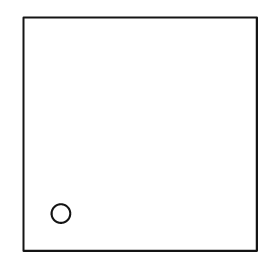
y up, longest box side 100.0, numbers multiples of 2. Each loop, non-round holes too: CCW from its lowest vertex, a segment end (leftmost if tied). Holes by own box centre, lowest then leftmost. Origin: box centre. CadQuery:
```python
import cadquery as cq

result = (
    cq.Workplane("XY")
    .moveTo(-50.0, -50.0)
    .lineTo(50.0, -50.0)
    .lineTo(50.0, 50.0)
    .lineTo(-50.0, 50.0)
    .close()
    .moveTo(-34.0, -34.0)
    .circle(4.0)
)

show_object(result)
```